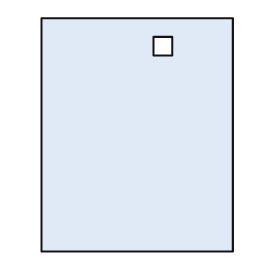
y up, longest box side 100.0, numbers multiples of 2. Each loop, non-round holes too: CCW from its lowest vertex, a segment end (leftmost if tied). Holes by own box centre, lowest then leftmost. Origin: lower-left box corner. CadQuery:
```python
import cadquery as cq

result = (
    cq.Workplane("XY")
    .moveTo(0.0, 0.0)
    .lineTo(82.0, 0.0)
    .lineTo(82.0, 100.0)
    .lineTo(0.0, 100.0)
    .close()
    .moveTo(48.0, 84.0)
    .lineTo(56.0, 84.0)
    .lineTo(56.0, 92.0)
    .lineTo(48.0, 92.0)
    .close()
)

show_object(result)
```